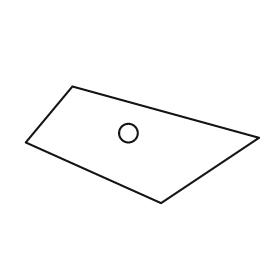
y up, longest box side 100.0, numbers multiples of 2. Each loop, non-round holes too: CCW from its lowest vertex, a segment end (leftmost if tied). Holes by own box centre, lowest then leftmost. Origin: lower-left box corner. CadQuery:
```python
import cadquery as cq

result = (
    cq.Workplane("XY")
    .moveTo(58.0, 0.0)
    .lineTo(100.0, 28.0)
    .lineTo(20.0, 50.0)
    .lineTo(0.0, 26.0)
    .close()
    .moveTo(44.0, 30.0)
    .circle(4.0)
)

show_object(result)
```